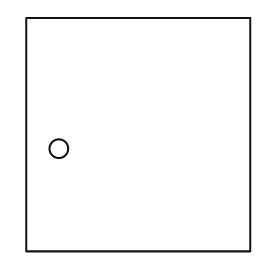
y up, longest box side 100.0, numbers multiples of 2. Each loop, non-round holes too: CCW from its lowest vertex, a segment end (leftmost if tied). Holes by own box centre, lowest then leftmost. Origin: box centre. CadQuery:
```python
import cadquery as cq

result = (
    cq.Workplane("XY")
    .moveTo(-48.0, -50.0)
    .lineTo(48.0, -50.0)
    .lineTo(48.0, 50.0)
    .lineTo(-48.0, 50.0)
    .close()
    .moveTo(-34.0, -6.0)
    .circle(4.0)
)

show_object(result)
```